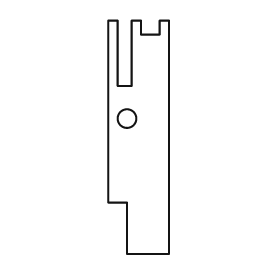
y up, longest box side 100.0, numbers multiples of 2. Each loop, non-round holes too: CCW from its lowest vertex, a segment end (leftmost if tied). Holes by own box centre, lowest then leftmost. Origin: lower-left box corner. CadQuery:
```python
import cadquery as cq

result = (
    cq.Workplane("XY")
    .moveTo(8.0, 0.0)
    .lineTo(26.0, 0.0)
    .lineTo(26.0, 100.0)
    .lineTo(22.0, 100.0)
    .lineTo(22.0, 94.0)
    .lineTo(14.0, 94.0)
    .lineTo(14.0, 100.0)
    .lineTo(10.0, 100.0)
    .lineTo(10.0, 72.0)
    .lineTo(4.0, 72.0)
    .lineTo(4.0, 100.0)
    .lineTo(0.0, 100.0)
    .lineTo(0.0, 22.0)
    .lineTo(8.0, 22.0)
    .close()
    .moveTo(8.0, 58.0)
    .circle(4.0)
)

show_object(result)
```